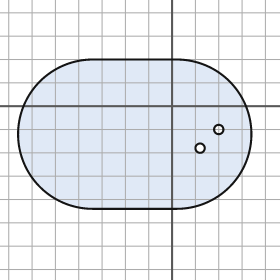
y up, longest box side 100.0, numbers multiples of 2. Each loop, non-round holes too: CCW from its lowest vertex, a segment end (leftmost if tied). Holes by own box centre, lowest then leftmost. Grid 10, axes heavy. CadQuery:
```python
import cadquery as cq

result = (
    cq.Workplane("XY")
    .moveTo(-34.0, -44.0)
    .lineTo(2.0, -44.0)
    .threePointArc((34.0, -12.0), (2.0, 20.0))
    .lineTo(-34.0, 20.0)
    .threePointArc((-66.0, -12.0), (-34.0, -44.0))
    .close()
    .moveTo(12.0, -18.0)
    .circle(2.0)
    .moveTo(20.0, -10.0)
    .circle(2.0)
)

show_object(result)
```